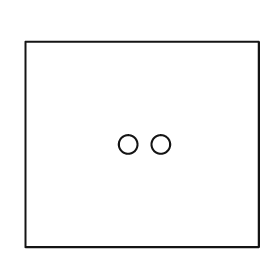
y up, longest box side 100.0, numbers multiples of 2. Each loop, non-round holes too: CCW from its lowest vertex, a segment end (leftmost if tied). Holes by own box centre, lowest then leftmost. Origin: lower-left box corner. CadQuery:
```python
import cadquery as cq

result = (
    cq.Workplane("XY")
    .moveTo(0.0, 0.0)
    .lineTo(100.0, 0.0)
    .lineTo(100.0, 88.0)
    .lineTo(0.0, 88.0)
    .close()
    .moveTo(44.0, 44.0)
    .circle(4.0)
    .moveTo(58.0, 44.0)
    .circle(4.0)
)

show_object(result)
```